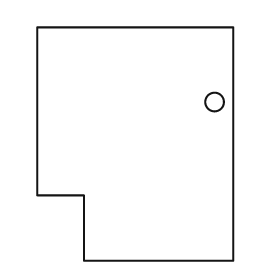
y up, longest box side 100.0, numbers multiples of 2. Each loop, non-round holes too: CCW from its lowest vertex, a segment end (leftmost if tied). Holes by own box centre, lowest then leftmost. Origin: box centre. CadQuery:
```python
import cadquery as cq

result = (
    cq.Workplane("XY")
    .moveTo(-22.0, -50.0)
    .lineTo(42.0, -50.0)
    .lineTo(42.0, 50.0)
    .lineTo(-42.0, 50.0)
    .lineTo(-42.0, -22.0)
    .lineTo(-22.0, -22.0)
    .close()
    .moveTo(34.0, 18.0)
    .circle(4.0)
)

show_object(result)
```